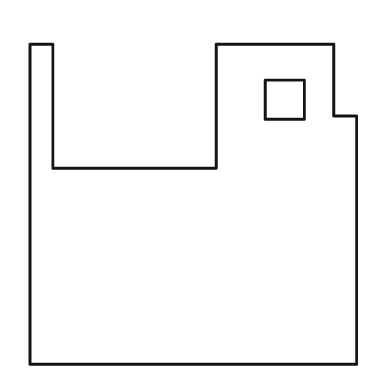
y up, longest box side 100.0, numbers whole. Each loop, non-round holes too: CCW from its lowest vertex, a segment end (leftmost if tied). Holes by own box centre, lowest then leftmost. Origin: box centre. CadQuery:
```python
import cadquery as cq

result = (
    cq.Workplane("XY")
    .moveTo(-50.0, -49.0)
    .lineTo(50.0, -49.0)
    .lineTo(50.0, 27.0)
    .lineTo(43.0, 27.0)
    .lineTo(43.0, 49.0)
    .lineTo(7.0, 49.0)
    .lineTo(7.0, 11.0)
    .lineTo(-43.0, 11.0)
    .lineTo(-43.0, 49.0)
    .lineTo(-50.0, 49.0)
    .close()
    .moveTo(22.0, 26.0)
    .lineTo(34.0, 26.0)
    .lineTo(34.0, 38.0)
    .lineTo(22.0, 38.0)
    .close()
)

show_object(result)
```